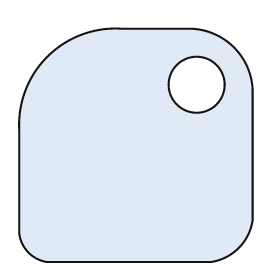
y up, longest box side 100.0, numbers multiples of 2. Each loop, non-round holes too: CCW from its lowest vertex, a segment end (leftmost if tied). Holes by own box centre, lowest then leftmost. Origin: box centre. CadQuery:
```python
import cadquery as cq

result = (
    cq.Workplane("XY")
    .moveTo(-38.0, -50.0)
    .lineTo(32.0, -50.0)
    .threePointArc((44.0, -44.0), (50.0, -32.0))
    .lineTo(50.0, 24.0)
    .threePointArc((42.0, 42.0), (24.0, 50.0))
    .lineTo(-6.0, 50.0)
    .threePointArc((-38.0, 38.0), (-50.0, 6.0))
    .lineTo(-50.0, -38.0)
    .threePointArc((-46.0, -46.0), (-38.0, -50.0))
    .close()
    .moveTo(26.0, 26.0)
    .circle(12.0)
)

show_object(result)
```